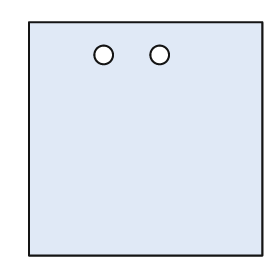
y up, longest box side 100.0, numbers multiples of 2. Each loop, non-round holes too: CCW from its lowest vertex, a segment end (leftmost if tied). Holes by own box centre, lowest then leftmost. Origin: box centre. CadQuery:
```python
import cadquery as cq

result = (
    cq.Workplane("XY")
    .moveTo(-50.0, -50.0)
    .lineTo(50.0, -50.0)
    .lineTo(50.0, 50.0)
    .lineTo(-50.0, 50.0)
    .close()
    .moveTo(-18.0, 36.0)
    .circle(4.0)
    .moveTo(6.0, 36.0)
    .circle(4.0)
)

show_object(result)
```